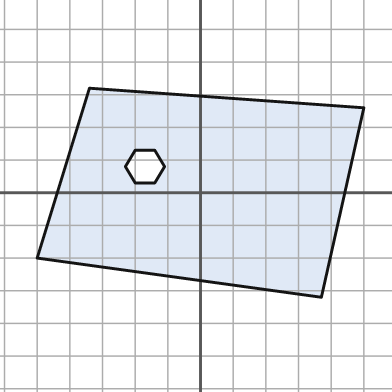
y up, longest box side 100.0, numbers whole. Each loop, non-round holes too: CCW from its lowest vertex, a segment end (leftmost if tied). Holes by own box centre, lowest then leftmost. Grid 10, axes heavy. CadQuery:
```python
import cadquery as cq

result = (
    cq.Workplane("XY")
    .moveTo(37.0, -32.0)
    .lineTo(50.0, 26.0)
    .lineTo(-34.0, 32.0)
    .lineTo(-50.0, -20.0)
    .close()
    .moveTo(-20.0, 3.0)
    .lineTo(-14.0, 3.0)
    .lineTo(-11.0, 8.0)
    .lineTo(-14.0, 13.0)
    .lineTo(-20.0, 13.0)
    .lineTo(-23.0, 8.0)
    .close()
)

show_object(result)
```